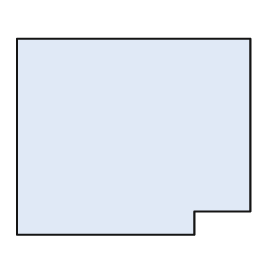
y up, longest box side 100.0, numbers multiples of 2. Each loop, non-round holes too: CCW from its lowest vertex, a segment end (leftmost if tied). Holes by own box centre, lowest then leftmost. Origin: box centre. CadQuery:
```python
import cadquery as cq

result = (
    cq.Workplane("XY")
    .moveTo(-50.0, -42.0)
    .lineTo(26.0, -42.0)
    .lineTo(26.0, -32.0)
    .lineTo(50.0, -32.0)
    .lineTo(50.0, 42.0)
    .lineTo(-50.0, 42.0)
    .close()
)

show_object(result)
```